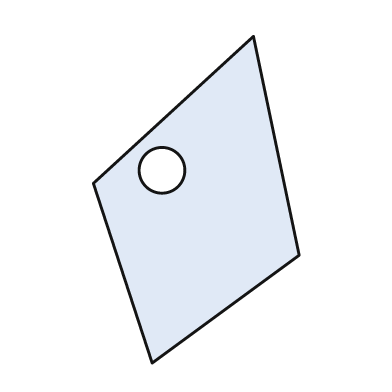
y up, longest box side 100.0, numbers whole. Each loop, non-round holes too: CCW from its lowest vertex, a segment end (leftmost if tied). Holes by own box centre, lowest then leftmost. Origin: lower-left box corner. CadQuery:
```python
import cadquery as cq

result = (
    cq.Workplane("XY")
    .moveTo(18.0, 0.0)
    .lineTo(63.0, 33.0)
    .lineTo(49.0, 100.0)
    .lineTo(0.0, 55.0)
    .close()
    .moveTo(21.0, 59.0)
    .circle(7.0)
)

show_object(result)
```